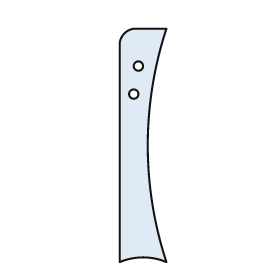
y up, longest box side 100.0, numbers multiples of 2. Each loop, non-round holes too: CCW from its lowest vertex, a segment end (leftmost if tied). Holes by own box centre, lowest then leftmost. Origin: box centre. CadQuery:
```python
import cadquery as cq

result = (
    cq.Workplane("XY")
    .moveTo(-10.0, -50.0)
    .threePointArc((0.0, -48.0), (10.0, -50.0))
    .threePointArc((2.0, 0.0), (10.0, 50.0))
    .lineTo(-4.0, 50.0)
    .threePointArc((-8.0, 48.0), (-10.0, 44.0))
    .close()
    .moveTo(-4.0, 22.0)
    .circle(2.0)
    .moveTo(-2.0, 34.0)
    .circle(2.0)
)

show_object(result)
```